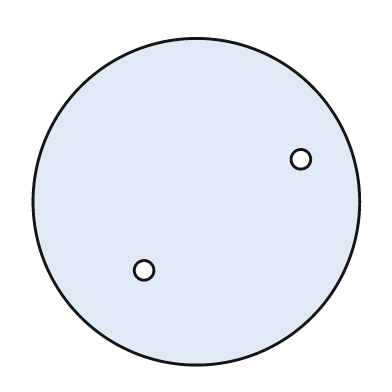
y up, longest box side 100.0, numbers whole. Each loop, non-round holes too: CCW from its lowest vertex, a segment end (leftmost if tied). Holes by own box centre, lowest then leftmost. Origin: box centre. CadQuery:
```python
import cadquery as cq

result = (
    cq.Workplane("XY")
    .moveTo(0.0, 0.0)
    .circle(50.0)
    .moveTo(-16.0, -21.0)
    .circle(3.0)
    .moveTo(32.0, 13.0)
    .circle(3.0)
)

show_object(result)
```